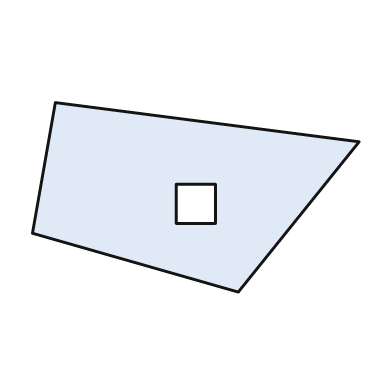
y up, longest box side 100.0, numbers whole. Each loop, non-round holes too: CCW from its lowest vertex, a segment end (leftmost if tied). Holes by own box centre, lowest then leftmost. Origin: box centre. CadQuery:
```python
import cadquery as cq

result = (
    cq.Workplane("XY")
    .moveTo(13.0, -29.0)
    .lineTo(50.0, 17.0)
    .lineTo(-43.0, 29.0)
    .lineTo(-50.0, -11.0)
    .close()
    .moveTo(-6.0, -8.0)
    .lineTo(6.0, -8.0)
    .lineTo(6.0, 4.0)
    .lineTo(-6.0, 4.0)
    .close()
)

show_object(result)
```